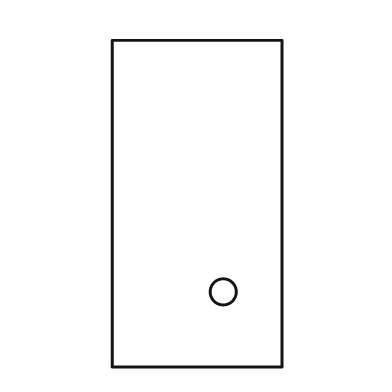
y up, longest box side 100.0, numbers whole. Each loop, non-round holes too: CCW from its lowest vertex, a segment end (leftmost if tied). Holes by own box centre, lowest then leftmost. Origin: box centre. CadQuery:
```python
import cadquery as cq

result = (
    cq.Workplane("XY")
    .moveTo(-26.0, -50.0)
    .lineTo(26.0, -50.0)
    .lineTo(26.0, 50.0)
    .lineTo(-26.0, 50.0)
    .close()
    .moveTo(8.0, -27.0)
    .circle(4.0)
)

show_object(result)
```